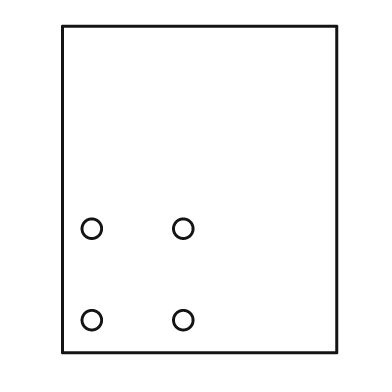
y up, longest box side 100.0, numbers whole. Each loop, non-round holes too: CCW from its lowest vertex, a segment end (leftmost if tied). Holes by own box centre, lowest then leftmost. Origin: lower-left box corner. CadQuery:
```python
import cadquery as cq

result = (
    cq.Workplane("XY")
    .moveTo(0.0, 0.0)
    .lineTo(84.0, 0.0)
    .lineTo(84.0, 100.0)
    .lineTo(0.0, 100.0)
    .close()
    .moveTo(9.0, 10.0)
    .circle(3.0)
    .moveTo(37.0, 10.0)
    .circle(3.0)
    .moveTo(9.0, 38.0)
    .circle(3.0)
    .moveTo(37.0, 38.0)
    .circle(3.0)
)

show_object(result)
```